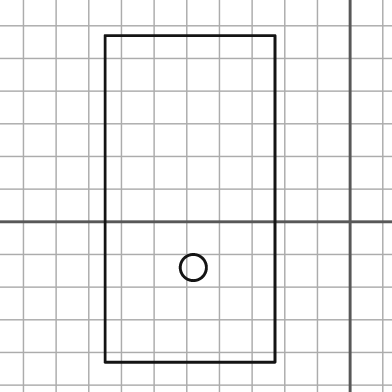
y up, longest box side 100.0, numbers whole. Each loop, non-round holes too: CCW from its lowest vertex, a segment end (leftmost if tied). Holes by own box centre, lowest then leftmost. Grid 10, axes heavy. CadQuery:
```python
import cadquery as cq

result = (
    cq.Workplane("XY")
    .moveTo(-75.0, -43.0)
    .lineTo(-23.0, -43.0)
    .lineTo(-23.0, 57.0)
    .lineTo(-75.0, 57.0)
    .close()
    .moveTo(-48.0, -14.0)
    .circle(4.0)
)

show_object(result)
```